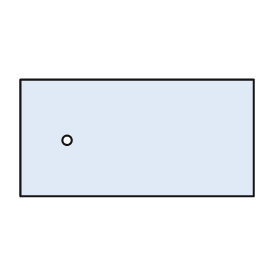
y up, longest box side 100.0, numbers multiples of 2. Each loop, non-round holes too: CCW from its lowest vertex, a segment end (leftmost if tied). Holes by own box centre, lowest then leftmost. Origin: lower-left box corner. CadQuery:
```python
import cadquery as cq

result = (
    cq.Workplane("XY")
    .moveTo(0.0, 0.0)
    .lineTo(100.0, 0.0)
    .lineTo(100.0, 50.0)
    .lineTo(0.0, 50.0)
    .close()
    .moveTo(20.0, 24.0)
    .circle(2.0)
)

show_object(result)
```